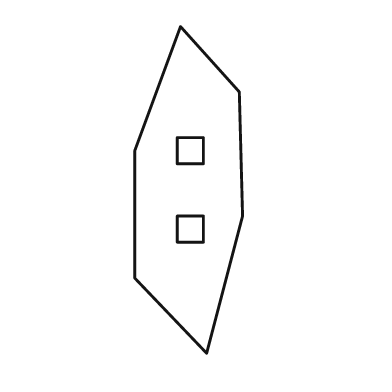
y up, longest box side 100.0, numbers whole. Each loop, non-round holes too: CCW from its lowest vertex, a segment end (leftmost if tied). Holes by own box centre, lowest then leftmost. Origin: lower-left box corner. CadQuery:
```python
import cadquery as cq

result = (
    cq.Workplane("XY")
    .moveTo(22.0, 0.0)
    .lineTo(33.0, 42.0)
    .lineTo(32.0, 80.0)
    .lineTo(14.0, 100.0)
    .lineTo(0.0, 62.0)
    .lineTo(0.0, 23.0)
    .close()
    .moveTo(13.0, 34.0)
    .lineTo(21.0, 34.0)
    .lineTo(21.0, 42.0)
    .lineTo(13.0, 42.0)
    .close()
    .moveTo(13.0, 58.0)
    .lineTo(21.0, 58.0)
    .lineTo(21.0, 66.0)
    .lineTo(13.0, 66.0)
    .close()
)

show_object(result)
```